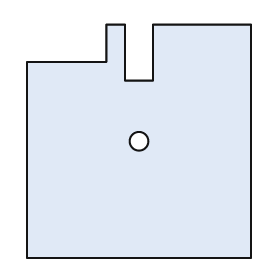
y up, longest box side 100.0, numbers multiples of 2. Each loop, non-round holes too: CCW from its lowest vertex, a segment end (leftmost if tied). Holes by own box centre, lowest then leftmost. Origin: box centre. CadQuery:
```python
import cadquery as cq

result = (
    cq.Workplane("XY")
    .moveTo(-48.0, -50.0)
    .lineTo(48.0, -50.0)
    .lineTo(48.0, 50.0)
    .lineTo(6.0, 50.0)
    .lineTo(6.0, 26.0)
    .lineTo(-6.0, 26.0)
    .lineTo(-6.0, 50.0)
    .lineTo(-14.0, 50.0)
    .lineTo(-14.0, 34.0)
    .lineTo(-48.0, 34.0)
    .close()
    .moveTo(0.0, 0.0)
    .circle(4.0)
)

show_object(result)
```